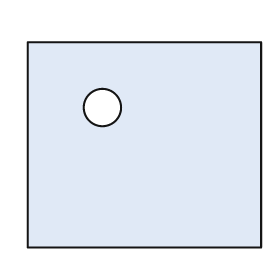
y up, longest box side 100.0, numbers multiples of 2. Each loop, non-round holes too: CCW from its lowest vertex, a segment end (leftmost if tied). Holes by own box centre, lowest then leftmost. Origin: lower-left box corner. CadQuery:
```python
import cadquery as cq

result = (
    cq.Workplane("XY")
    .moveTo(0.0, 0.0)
    .lineTo(100.0, 0.0)
    .lineTo(100.0, 88.0)
    .lineTo(0.0, 88.0)
    .close()
    .moveTo(32.0, 60.0)
    .circle(8.0)
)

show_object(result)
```